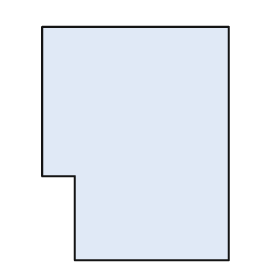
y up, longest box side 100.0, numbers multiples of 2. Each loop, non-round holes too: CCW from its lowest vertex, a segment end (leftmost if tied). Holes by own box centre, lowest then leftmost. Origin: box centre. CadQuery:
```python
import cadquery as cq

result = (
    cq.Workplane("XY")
    .moveTo(-26.0, -50.0)
    .lineTo(40.0, -50.0)
    .lineTo(40.0, 50.0)
    .lineTo(-40.0, 50.0)
    .lineTo(-40.0, -14.0)
    .lineTo(-26.0, -14.0)
    .close()
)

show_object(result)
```